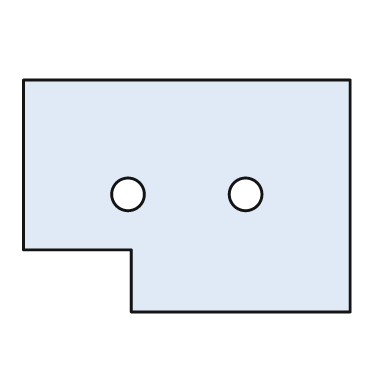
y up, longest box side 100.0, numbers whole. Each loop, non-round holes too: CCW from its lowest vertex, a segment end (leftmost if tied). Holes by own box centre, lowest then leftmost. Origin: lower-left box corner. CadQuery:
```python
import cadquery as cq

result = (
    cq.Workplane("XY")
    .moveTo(33.0, 0.0)
    .lineTo(100.0, 0.0)
    .lineTo(100.0, 71.0)
    .lineTo(0.0, 71.0)
    .lineTo(0.0, 19.0)
    .lineTo(33.0, 19.0)
    .close()
    .moveTo(32.0, 36.0)
    .circle(5.0)
    .moveTo(68.0, 36.0)
    .circle(5.0)
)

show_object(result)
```